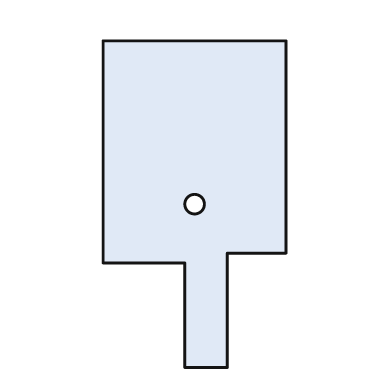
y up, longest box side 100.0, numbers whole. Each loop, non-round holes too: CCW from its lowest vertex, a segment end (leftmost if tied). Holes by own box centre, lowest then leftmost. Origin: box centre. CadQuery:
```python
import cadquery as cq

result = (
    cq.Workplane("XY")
    .moveTo(-3.0, -50.0)
    .lineTo(10.0, -50.0)
    .lineTo(10.0, -15.0)
    .lineTo(28.0, -15.0)
    .lineTo(28.0, 50.0)
    .lineTo(-28.0, 50.0)
    .lineTo(-28.0, -18.0)
    .lineTo(-3.0, -18.0)
    .close()
    .moveTo(0.0, 0.0)
    .circle(3.0)
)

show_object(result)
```